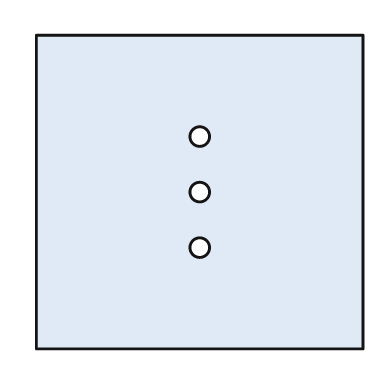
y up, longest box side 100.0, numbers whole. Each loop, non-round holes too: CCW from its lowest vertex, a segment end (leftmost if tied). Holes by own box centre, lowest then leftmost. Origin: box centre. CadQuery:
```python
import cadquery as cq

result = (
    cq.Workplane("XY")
    .moveTo(-50.0, -48.0)
    .lineTo(50.0, -48.0)
    .lineTo(50.0, 48.0)
    .lineTo(-50.0, 48.0)
    .close()
    .moveTo(0.0, -17.0)
    .circle(3.0)
    .moveTo(0.0, 0.0)
    .circle(3.0)
    .moveTo(0.0, 17.0)
    .circle(3.0)
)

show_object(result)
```